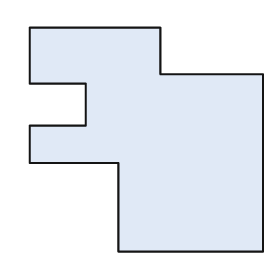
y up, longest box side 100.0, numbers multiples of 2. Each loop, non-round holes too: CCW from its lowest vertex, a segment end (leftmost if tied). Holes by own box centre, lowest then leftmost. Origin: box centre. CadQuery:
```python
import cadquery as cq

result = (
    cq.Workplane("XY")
    .moveTo(-12.0, -48.0)
    .lineTo(50.0, -48.0)
    .lineTo(50.0, 28.0)
    .lineTo(6.0, 28.0)
    .lineTo(6.0, 48.0)
    .lineTo(-50.0, 48.0)
    .lineTo(-50.0, 24.0)
    .lineTo(-26.0, 24.0)
    .lineTo(-26.0, 6.0)
    .lineTo(-50.0, 6.0)
    .lineTo(-50.0, -10.0)
    .lineTo(-12.0, -10.0)
    .close()
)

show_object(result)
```